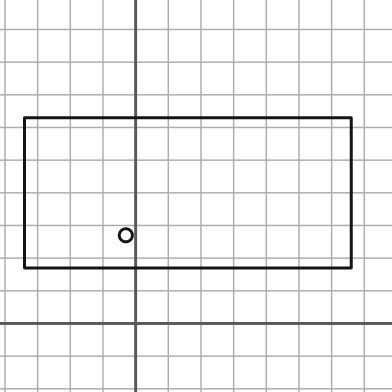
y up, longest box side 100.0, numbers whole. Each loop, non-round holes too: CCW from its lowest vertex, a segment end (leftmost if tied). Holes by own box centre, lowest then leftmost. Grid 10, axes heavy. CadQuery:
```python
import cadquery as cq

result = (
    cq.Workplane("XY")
    .moveTo(-34.0, 17.0)
    .lineTo(66.0, 17.0)
    .lineTo(66.0, 63.0)
    .lineTo(-34.0, 63.0)
    .close()
    .moveTo(-3.0, 27.0)
    .circle(2.0)
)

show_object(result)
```